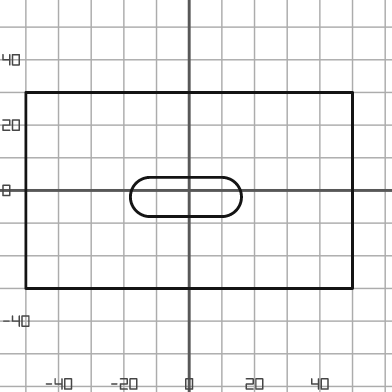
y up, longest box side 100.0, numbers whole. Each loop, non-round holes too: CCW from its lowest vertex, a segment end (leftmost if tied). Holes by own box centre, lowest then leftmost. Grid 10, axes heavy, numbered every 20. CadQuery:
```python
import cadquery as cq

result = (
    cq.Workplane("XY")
    .moveTo(-50.0, -30.0)
    .lineTo(50.0, -30.0)
    .lineTo(50.0, 30.0)
    .lineTo(-50.0, 30.0)
    .close()
    .moveTo(-12.0, -8.0)
    .lineTo(10.0, -8.0)
    .threePointArc((16.0, -2.0), (10.0, 4.0))
    .lineTo(-12.0, 4.0)
    .threePointArc((-18.0, -2.0), (-12.0, -8.0))
    .close()
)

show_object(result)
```